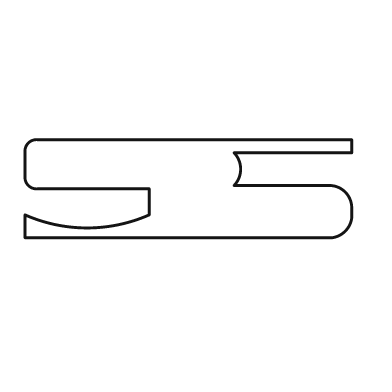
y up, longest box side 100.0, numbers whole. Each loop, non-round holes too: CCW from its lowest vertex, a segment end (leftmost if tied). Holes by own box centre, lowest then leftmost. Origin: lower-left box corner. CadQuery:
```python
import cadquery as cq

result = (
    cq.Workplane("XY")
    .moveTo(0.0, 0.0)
    .lineTo(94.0, 0.0)
    .threePointArc((98.0, 2.0), (100.0, 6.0))
    .lineTo(100.0, 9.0)
    .threePointArc((98.0, 14.0), (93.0, 16.0))
    .lineTo(64.0, 16.0)
    .threePointArc((66.0, 21.0), (64.0, 26.0))
    .lineTo(100.0, 26.0)
    .lineTo(100.0, 30.0)
    .lineTo(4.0, 30.0)
    .threePointArc((1.0, 29.0), (0.0, 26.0))
    .lineTo(0.0, 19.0)
    .threePointArc((1.0, 16.0), (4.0, 15.0))
    .lineTo(38.0, 15.0)
    .lineTo(38.0, 7.0)
    .threePointArc((19.0, 3.0), (0.0, 7.0))
    .close()
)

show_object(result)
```